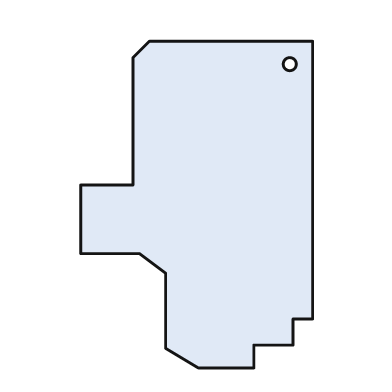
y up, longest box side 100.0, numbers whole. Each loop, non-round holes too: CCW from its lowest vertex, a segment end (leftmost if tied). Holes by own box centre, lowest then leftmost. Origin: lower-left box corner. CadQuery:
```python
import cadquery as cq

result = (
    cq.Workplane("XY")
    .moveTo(36.0, 0.0)
    .lineTo(53.0, 0.0)
    .lineTo(53.0, 7.0)
    .lineTo(65.0, 7.0)
    .lineTo(65.0, 15.0)
    .lineTo(71.0, 15.0)
    .lineTo(71.0, 100.0)
    .lineTo(21.0, 100.0)
    .lineTo(16.0, 95.0)
    .lineTo(16.0, 56.0)
    .lineTo(0.0, 56.0)
    .lineTo(0.0, 35.0)
    .lineTo(18.0, 35.0)
    .lineTo(26.0, 29.0)
    .lineTo(26.0, 6.0)
    .close()
    .moveTo(64.0, 93.0)
    .circle(2.0)
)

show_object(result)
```